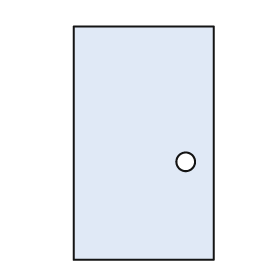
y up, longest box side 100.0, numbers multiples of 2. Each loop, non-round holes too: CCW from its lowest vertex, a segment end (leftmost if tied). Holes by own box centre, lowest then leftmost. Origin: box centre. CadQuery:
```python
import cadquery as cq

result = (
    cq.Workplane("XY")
    .moveTo(-30.0, -50.0)
    .lineTo(30.0, -50.0)
    .lineTo(30.0, 50.0)
    .lineTo(-30.0, 50.0)
    .close()
    .moveTo(18.0, -8.0)
    .circle(4.0)
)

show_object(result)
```